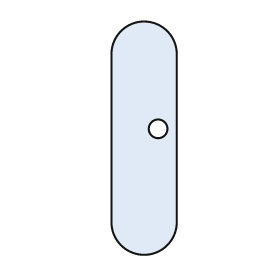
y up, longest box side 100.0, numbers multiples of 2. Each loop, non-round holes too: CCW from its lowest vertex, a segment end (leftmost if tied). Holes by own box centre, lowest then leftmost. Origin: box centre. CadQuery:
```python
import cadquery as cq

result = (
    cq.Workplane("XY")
    .moveTo(-14.0, -36.0)
    .threePointArc((0.0, -50.0), (14.0, -36.0))
    .lineTo(14.0, 36.0)
    .threePointArc((0.0, 50.0), (-14.0, 36.0))
    .close()
    .moveTo(6.0, 4.0)
    .circle(4.0)
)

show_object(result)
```